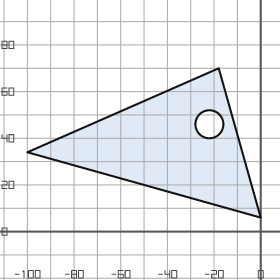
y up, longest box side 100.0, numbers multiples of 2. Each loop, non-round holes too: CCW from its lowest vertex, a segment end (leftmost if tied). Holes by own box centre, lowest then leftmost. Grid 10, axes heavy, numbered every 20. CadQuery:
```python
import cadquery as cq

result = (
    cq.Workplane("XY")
    .moveTo(0.0, 6.0)
    .lineTo(-18.0, 70.0)
    .lineTo(-100.0, 34.0)
    .close()
    .moveTo(-22.0, 46.0)
    .circle(6.0)
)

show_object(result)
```